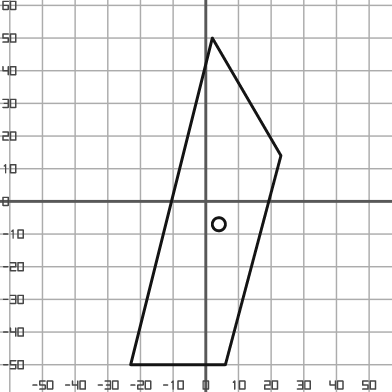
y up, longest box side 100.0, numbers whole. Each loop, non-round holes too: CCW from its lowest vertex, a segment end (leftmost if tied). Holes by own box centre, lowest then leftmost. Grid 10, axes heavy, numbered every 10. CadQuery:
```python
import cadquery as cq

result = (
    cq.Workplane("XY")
    .moveTo(-23.0, -50.0)
    .lineTo(6.0, -50.0)
    .lineTo(23.0, 14.0)
    .lineTo(2.0, 50.0)
    .close()
    .moveTo(4.0, -7.0)
    .circle(2.0)
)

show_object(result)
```